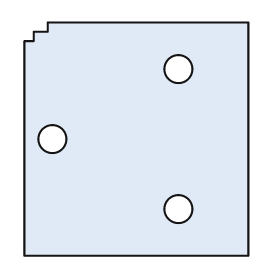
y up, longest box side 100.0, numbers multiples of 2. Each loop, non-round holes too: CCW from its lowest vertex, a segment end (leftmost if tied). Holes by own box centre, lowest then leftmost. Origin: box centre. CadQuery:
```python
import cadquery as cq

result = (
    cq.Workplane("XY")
    .moveTo(-48.0, -50.0)
    .lineTo(48.0, -50.0)
    .lineTo(48.0, 50.0)
    .lineTo(-38.0, 50.0)
    .lineTo(-38.0, 46.0)
    .lineTo(-44.0, 46.0)
    .lineTo(-44.0, 42.0)
    .lineTo(-48.0, 42.0)
    .close()
    .moveTo(18.0, -30.0)
    .circle(6.0)
    .moveTo(-36.0, 0.0)
    .circle(6.0)
    .moveTo(18.0, 30.0)
    .circle(6.0)
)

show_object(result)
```